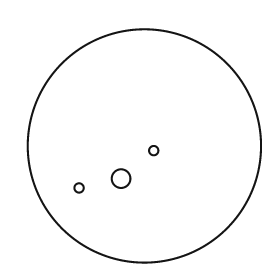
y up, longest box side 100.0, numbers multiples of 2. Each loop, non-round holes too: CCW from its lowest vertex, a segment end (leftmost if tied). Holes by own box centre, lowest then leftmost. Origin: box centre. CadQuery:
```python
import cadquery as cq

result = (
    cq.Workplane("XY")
    .moveTo(0.0, 0.0)
    .circle(50.0)
    .moveTo(-28.0, -18.0)
    .circle(2.0)
    .moveTo(-10.0, -14.0)
    .circle(4.0)
    .moveTo(4.0, -2.0)
    .circle(2.0)
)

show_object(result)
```